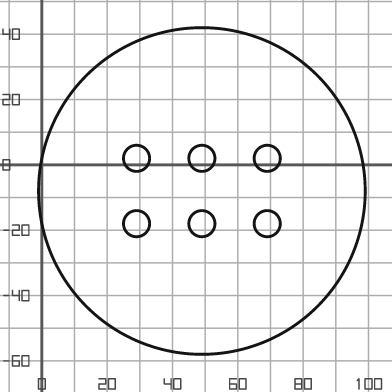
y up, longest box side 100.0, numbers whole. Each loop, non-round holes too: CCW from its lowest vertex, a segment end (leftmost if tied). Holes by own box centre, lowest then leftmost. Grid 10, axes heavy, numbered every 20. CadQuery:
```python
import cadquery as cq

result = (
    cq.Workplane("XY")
    .moveTo(49.0, -8.0)
    .circle(50.0)
    .moveTo(29.0, -18.0)
    .circle(4.0)
    .moveTo(49.0, -18.0)
    .circle(4.0)
    .moveTo(69.0, -18.0)
    .circle(4.0)
    .moveTo(29.0, 2.0)
    .circle(4.0)
    .moveTo(49.0, 2.0)
    .circle(4.0)
    .moveTo(69.0, 2.0)
    .circle(4.0)
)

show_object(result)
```